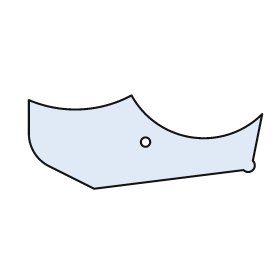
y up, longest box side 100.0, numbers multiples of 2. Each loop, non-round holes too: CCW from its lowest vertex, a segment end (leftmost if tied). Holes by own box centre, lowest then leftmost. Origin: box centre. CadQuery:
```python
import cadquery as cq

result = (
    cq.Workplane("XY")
    .moveTo(-22.0, -20.0)
    .lineTo(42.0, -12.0)
    .threePointArc((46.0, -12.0), (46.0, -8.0))
    .lineTo(50.0, 12.0)
    .threePointArc((20.0, 2.0), (-6.0, 20.0))
    .threePointArc((-28.0, 14.0), (-50.0, 18.0))
    .lineTo(-50.0, 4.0)
    .threePointArc((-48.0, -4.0), (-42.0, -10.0))
    .close()
    .moveTo(0.0, 0.0)
    .circle(2.0)
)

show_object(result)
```